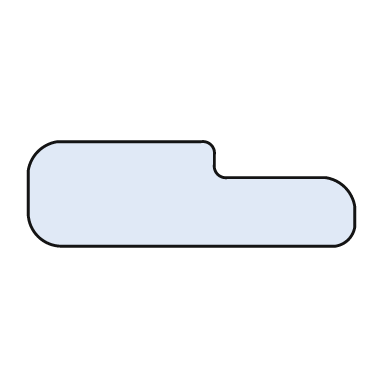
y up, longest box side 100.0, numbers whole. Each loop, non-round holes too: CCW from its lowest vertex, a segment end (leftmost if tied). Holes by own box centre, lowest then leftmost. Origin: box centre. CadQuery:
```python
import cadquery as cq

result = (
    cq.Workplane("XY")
    .moveTo(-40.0, -16.0)
    .lineTo(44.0, -16.0)
    .threePointArc((48.0, -14.0), (50.0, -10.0))
    .lineTo(50.0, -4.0)
    .threePointArc((47.0, 2.0), (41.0, 5.0))
    .lineTo(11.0, 5.0)
    .threePointArc((8.0, 6.0), (7.0, 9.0))
    .lineTo(7.0, 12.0)
    .threePointArc((6.0, 15.0), (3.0, 16.0))
    .lineTo(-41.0, 16.0)
    .threePointArc((-47.0, 13.0), (-50.0, 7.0))
    .lineTo(-50.0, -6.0)
    .threePointArc((-47.0, -13.0), (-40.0, -16.0))
    .close()
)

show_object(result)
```